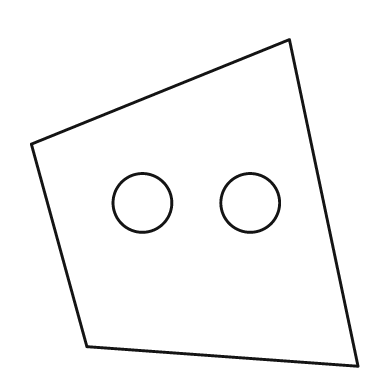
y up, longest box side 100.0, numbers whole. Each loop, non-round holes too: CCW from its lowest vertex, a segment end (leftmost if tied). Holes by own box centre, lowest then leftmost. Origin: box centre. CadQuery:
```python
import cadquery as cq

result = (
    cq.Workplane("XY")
    .moveTo(50.0, -50.0)
    .lineTo(29.0, 50.0)
    .lineTo(-50.0, 18.0)
    .lineTo(-33.0, -44.0)
    .close()
    .moveTo(-16.0, 0.0)
    .circle(9.0)
    .moveTo(17.0, 0.0)
    .circle(9.0)
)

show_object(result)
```